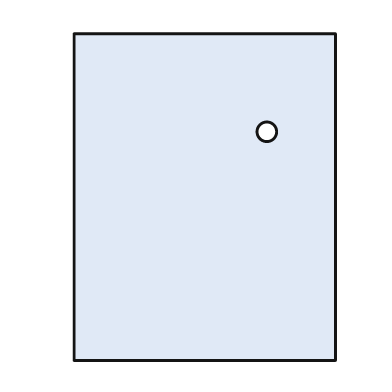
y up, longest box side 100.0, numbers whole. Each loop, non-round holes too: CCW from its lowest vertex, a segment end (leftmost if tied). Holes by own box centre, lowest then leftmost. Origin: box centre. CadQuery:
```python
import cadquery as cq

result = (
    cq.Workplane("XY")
    .moveTo(-40.0, -50.0)
    .lineTo(40.0, -50.0)
    .lineTo(40.0, 50.0)
    .lineTo(-40.0, 50.0)
    .close()
    .moveTo(19.0, 20.0)
    .circle(3.0)
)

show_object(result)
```